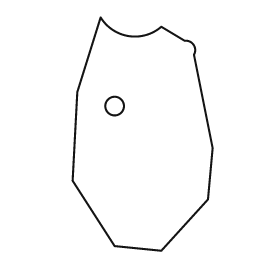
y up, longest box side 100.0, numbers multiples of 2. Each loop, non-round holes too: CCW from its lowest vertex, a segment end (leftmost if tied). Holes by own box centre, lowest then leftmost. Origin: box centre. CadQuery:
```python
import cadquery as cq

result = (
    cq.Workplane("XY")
    .moveTo(8.0, -50.0)
    .lineTo(28.0, -28.0)
    .lineTo(30.0, -6.0)
    .lineTo(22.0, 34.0)
    .threePointArc((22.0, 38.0), (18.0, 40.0))
    .lineTo(8.0, 46.0)
    .threePointArc((-6.0, 42.0), (-18.0, 50.0))
    .lineTo(-28.0, 18.0)
    .lineTo(-30.0, -20.0)
    .lineTo(-12.0, -48.0)
    .close()
    .moveTo(-12.0, 12.0)
    .circle(4.0)
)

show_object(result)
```